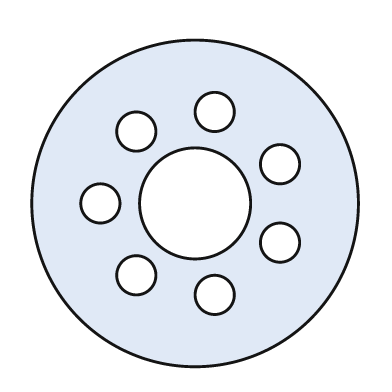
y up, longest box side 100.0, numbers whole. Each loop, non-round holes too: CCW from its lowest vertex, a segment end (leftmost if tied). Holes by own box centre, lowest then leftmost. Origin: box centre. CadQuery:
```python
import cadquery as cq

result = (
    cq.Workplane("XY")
    .moveTo(0.0, 0.0)
    .circle(50.0)
    .moveTo(6.0, -28.0)
    .circle(6.0)
    .moveTo(-18.0, -22.0)
    .circle(6.0)
    .moveTo(26.0, -12.0)
    .circle(6.0)
    .moveTo(-29.0, 0.0)
    .circle(6.0)
    .moveTo(0.0, 0.0)
    .circle(17.0)
    .moveTo(26.0, 12.0)
    .circle(6.0)
    .moveTo(-18.0, 22.0)
    .circle(6.0)
    .moveTo(6.0, 28.0)
    .circle(6.0)
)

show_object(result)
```